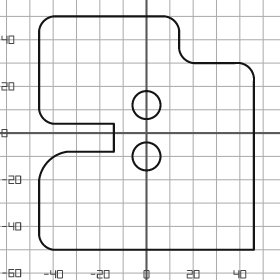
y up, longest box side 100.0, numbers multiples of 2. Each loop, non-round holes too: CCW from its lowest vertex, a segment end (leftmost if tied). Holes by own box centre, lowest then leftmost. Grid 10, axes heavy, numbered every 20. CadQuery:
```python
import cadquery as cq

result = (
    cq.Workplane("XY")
    .moveTo(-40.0, -50.0)
    .lineTo(46.0, -50.0)
    .lineTo(46.0, 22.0)
    .threePointArc((44.0, 28.0), (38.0, 30.0))
    .lineTo(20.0, 30.0)
    .threePointArc((16.0, 32.0), (14.0, 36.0))
    .lineTo(14.0, 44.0)
    .threePointArc((12.0, 48.0), (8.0, 50.0))
    .lineTo(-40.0, 50.0)
    .threePointArc((-44.0, 48.0), (-46.0, 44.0))
    .lineTo(-46.0, 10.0)
    .threePointArc((-44.0, 6.0), (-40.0, 4.0))
    .lineTo(-14.0, 4.0)
    .lineTo(-14.0, -8.0)
    .lineTo(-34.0, -8.0)
    .threePointArc((-42.0, -12.0), (-46.0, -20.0))
    .lineTo(-46.0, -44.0)
    .threePointArc((-44.0, -48.0), (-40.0, -50.0))
    .close()
    .moveTo(0.0, -10.0)
    .circle(6.0)
    .moveTo(0.0, 12.0)
    .circle(6.0)
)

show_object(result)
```